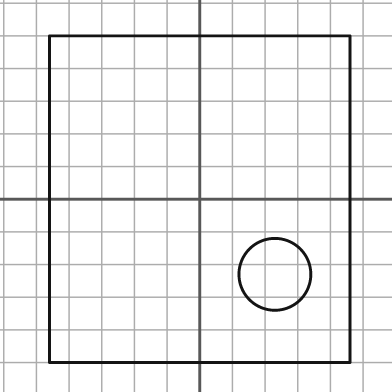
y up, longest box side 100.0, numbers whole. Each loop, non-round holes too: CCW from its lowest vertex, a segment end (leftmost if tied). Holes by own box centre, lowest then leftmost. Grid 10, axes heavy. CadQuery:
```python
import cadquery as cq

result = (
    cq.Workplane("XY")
    .moveTo(-46.0, -50.0)
    .lineTo(46.0, -50.0)
    .lineTo(46.0, 50.0)
    .lineTo(-46.0, 50.0)
    .close()
    .moveTo(23.0, -23.0)
    .circle(11.0)
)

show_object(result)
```